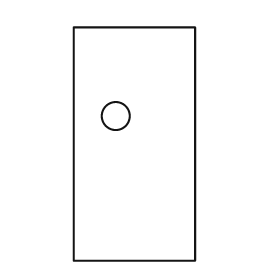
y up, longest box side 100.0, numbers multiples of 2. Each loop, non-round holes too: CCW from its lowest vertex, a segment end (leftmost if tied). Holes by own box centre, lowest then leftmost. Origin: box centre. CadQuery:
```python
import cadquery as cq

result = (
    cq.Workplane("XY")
    .moveTo(-26.0, -50.0)
    .lineTo(26.0, -50.0)
    .lineTo(26.0, 50.0)
    .lineTo(-26.0, 50.0)
    .close()
    .moveTo(-8.0, 12.0)
    .circle(6.0)
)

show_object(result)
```